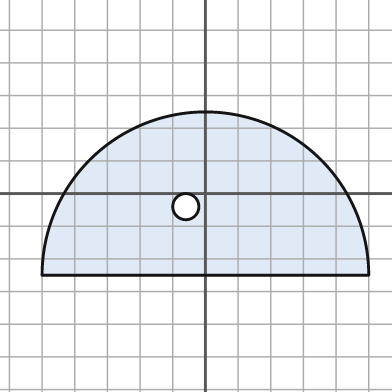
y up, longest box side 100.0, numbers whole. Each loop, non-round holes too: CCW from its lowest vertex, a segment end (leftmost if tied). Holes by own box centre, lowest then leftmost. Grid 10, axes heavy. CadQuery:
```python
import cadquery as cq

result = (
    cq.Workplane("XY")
    .moveTo(-50.0, -25.0)
    .lineTo(50.0, -25.0)
    .threePointArc((0.0, 25.0), (-50.0, -25.0))
    .close()
    .moveTo(-6.0, -4.0)
    .circle(4.0)
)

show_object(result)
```